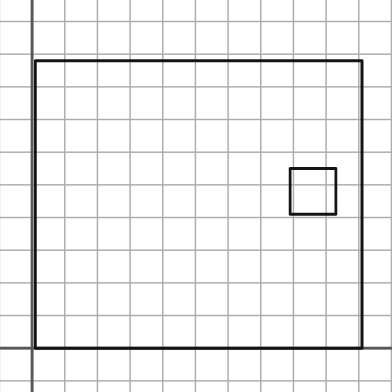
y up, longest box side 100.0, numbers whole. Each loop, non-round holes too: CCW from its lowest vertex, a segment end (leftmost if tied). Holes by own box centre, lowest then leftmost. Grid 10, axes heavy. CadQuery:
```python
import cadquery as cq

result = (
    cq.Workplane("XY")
    .moveTo(1.0, 0.0)
    .lineTo(101.0, 0.0)
    .lineTo(101.0, 88.0)
    .lineTo(1.0, 88.0)
    .close()
    .moveTo(79.0, 41.0)
    .lineTo(93.0, 41.0)
    .lineTo(93.0, 55.0)
    .lineTo(79.0, 55.0)
    .close()
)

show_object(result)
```